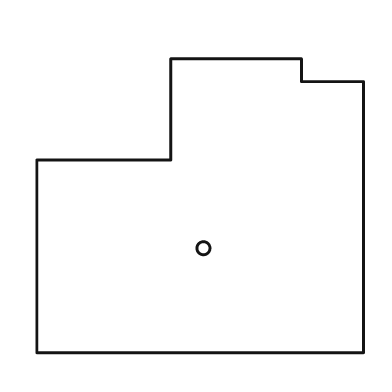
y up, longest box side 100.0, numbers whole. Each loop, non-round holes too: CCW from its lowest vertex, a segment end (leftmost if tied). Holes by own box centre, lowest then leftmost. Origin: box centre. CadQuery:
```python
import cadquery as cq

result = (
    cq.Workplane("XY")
    .moveTo(-50.0, -45.0)
    .lineTo(50.0, -45.0)
    .lineTo(50.0, 38.0)
    .lineTo(31.0, 38.0)
    .lineTo(31.0, 45.0)
    .lineTo(-9.0, 45.0)
    .lineTo(-9.0, 14.0)
    .lineTo(-50.0, 14.0)
    .close()
    .moveTo(1.0, -13.0)
    .circle(2.0)
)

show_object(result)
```